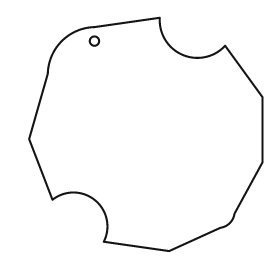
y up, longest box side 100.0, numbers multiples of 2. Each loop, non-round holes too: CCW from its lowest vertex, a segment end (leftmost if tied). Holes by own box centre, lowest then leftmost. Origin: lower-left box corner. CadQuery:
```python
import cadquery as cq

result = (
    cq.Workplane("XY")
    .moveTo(60.0, 0.0)
    .lineTo(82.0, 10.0)
    .threePointArc((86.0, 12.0), (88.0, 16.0))
    .lineTo(100.0, 38.0)
    .lineTo(100.0, 66.0)
    .lineTo(84.0, 88.0)
    .threePointArc((66.0, 84.0), (56.0, 100.0))
    .lineTo(28.0, 96.0)
    .threePointArc((14.0, 90.0), (8.0, 76.0))
    .lineTo(0.0, 48.0)
    .lineTo(10.0, 22.0)
    .threePointArc((28.0, 22.0), (32.0, 4.0))
    .close()
    .moveTo(28.0, 90.0)
    .circle(2.0)
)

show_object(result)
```